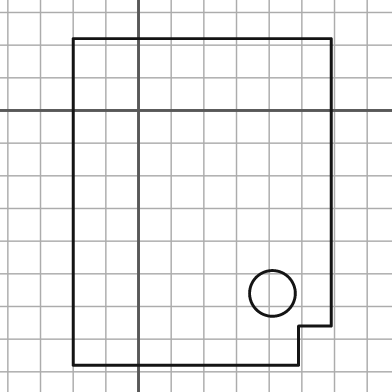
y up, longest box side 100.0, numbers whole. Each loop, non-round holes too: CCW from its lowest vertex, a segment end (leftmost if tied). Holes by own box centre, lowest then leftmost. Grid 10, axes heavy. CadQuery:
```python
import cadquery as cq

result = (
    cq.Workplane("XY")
    .moveTo(-20.0, -78.0)
    .lineTo(49.0, -78.0)
    .lineTo(49.0, -66.0)
    .lineTo(59.0, -66.0)
    .lineTo(59.0, 22.0)
    .lineTo(-20.0, 22.0)
    .close()
    .moveTo(41.0, -56.0)
    .circle(7.0)
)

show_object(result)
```